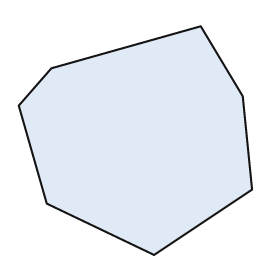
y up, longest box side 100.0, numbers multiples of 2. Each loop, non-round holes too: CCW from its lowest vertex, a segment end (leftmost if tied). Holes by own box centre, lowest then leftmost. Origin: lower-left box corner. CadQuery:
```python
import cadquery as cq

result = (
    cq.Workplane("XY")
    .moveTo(58.0, 0.0)
    .lineTo(100.0, 28.0)
    .lineTo(96.0, 68.0)
    .lineTo(78.0, 98.0)
    .lineTo(14.0, 80.0)
    .lineTo(0.0, 64.0)
    .lineTo(12.0, 22.0)
    .close()
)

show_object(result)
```